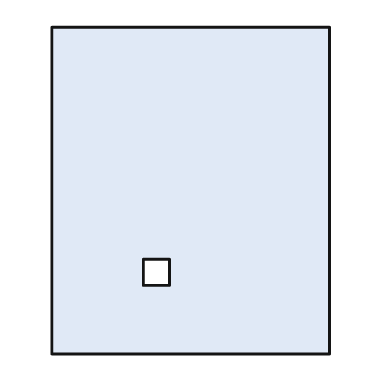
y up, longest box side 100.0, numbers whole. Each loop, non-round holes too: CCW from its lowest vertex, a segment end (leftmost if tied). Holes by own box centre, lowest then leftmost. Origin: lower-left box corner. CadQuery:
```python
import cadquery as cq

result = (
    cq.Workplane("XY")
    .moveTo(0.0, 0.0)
    .lineTo(85.0, 0.0)
    .lineTo(85.0, 100.0)
    .lineTo(0.0, 100.0)
    .close()
    .moveTo(28.0, 21.0)
    .lineTo(36.0, 21.0)
    .lineTo(36.0, 29.0)
    .lineTo(28.0, 29.0)
    .close()
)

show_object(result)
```